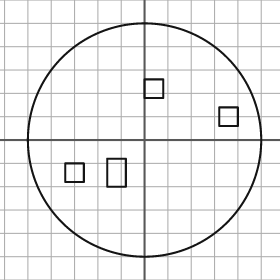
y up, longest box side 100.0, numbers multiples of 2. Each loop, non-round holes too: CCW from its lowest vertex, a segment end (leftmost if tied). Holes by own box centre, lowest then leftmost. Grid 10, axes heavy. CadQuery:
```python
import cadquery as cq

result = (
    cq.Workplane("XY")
    .moveTo(0.0, 0.0)
    .circle(50.0)
    .moveTo(-34.0, -18.0)
    .lineTo(-26.0, -18.0)
    .lineTo(-26.0, -10.0)
    .lineTo(-34.0, -10.0)
    .close()
    .moveTo(-16.0, -20.0)
    .lineTo(-8.0, -20.0)
    .lineTo(-8.0, -8.0)
    .lineTo(-16.0, -8.0)
    .close()
    .moveTo(32.0, 6.0)
    .lineTo(40.0, 6.0)
    .lineTo(40.0, 14.0)
    .lineTo(32.0, 14.0)
    .close()
    .moveTo(0.0, 18.0)
    .lineTo(8.0, 18.0)
    .lineTo(8.0, 26.0)
    .lineTo(0.0, 26.0)
    .close()
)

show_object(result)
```